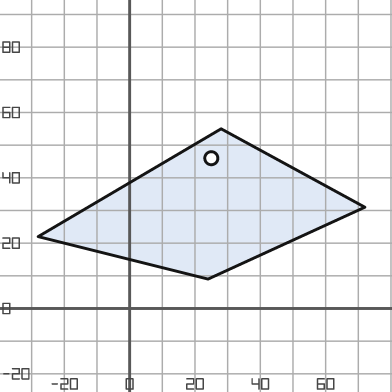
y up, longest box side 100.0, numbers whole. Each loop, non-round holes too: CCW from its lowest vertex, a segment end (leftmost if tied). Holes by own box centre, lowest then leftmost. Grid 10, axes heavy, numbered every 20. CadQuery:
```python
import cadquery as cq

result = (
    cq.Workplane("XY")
    .moveTo(24.0, 9.0)
    .lineTo(72.0, 31.0)
    .lineTo(28.0, 55.0)
    .lineTo(-28.0, 22.0)
    .close()
    .moveTo(25.0, 46.0)
    .circle(2.0)
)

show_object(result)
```